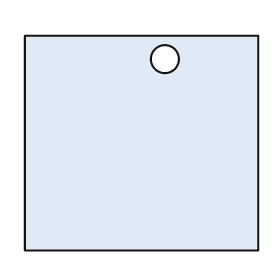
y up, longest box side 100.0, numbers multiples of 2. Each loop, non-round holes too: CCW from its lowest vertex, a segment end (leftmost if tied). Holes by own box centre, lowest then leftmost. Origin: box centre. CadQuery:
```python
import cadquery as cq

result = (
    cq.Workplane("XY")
    .moveTo(-50.0, -46.0)
    .lineTo(50.0, -46.0)
    .lineTo(50.0, 46.0)
    .lineTo(-50.0, 46.0)
    .close()
    .moveTo(10.0, 36.0)
    .circle(6.0)
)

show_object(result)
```